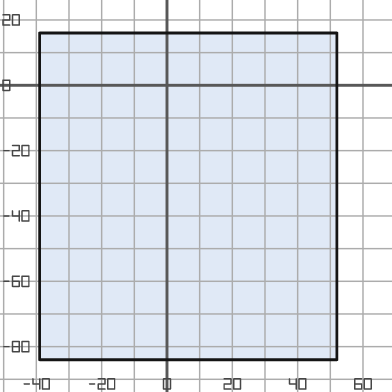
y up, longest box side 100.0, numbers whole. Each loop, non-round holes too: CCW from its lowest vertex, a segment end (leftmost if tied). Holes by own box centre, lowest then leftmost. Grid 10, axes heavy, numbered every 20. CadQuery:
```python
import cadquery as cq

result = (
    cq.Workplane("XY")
    .moveTo(-39.0, -84.0)
    .lineTo(52.0, -84.0)
    .lineTo(52.0, 16.0)
    .lineTo(-39.0, 16.0)
    .close()
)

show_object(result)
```